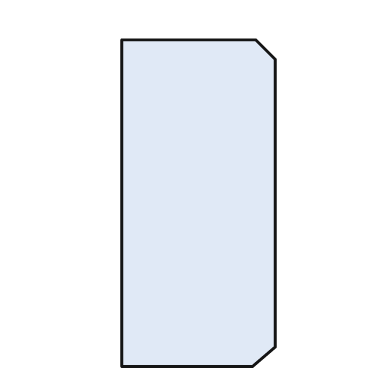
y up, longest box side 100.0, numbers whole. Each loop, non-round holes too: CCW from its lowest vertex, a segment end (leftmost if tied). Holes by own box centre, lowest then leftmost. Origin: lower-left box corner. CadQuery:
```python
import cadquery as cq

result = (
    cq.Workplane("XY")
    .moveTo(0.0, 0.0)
    .lineTo(40.0, 0.0)
    .lineTo(47.0, 6.0)
    .lineTo(47.0, 94.0)
    .lineTo(41.0, 100.0)
    .lineTo(0.0, 100.0)
    .close()
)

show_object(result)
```